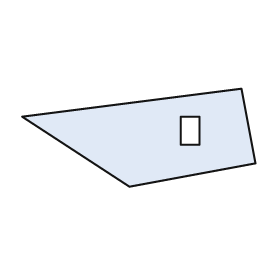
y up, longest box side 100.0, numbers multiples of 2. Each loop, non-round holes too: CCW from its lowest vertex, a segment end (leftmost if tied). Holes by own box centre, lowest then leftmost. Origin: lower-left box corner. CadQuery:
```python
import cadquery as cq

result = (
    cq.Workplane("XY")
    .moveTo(46.0, 0.0)
    .lineTo(100.0, 10.0)
    .lineTo(94.0, 42.0)
    .lineTo(0.0, 30.0)
    .close()
    .moveTo(68.0, 18.0)
    .lineTo(76.0, 18.0)
    .lineTo(76.0, 30.0)
    .lineTo(68.0, 30.0)
    .close()
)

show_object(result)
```